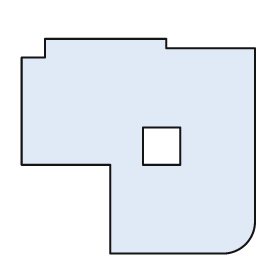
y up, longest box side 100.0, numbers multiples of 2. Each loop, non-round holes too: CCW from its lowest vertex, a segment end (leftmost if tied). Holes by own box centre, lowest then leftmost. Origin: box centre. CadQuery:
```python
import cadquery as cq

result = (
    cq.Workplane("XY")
    .moveTo(-12.0, -46.0)
    .lineTo(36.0, -46.0)
    .threePointArc((46.0, -42.0), (50.0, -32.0))
    .lineTo(50.0, 42.0)
    .lineTo(12.0, 42.0)
    .lineTo(12.0, 46.0)
    .lineTo(-40.0, 46.0)
    .lineTo(-40.0, 38.0)
    .lineTo(-50.0, 38.0)
    .lineTo(-50.0, -8.0)
    .lineTo(-12.0, -8.0)
    .close()
    .moveTo(2.0, -8.0)
    .lineTo(18.0, -8.0)
    .lineTo(18.0, 8.0)
    .lineTo(2.0, 8.0)
    .close()
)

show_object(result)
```